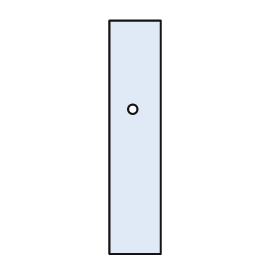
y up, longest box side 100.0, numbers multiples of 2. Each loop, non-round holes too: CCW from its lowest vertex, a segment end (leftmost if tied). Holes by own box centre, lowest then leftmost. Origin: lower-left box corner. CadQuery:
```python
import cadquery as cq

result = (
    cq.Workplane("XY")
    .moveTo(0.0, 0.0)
    .lineTo(22.0, 0.0)
    .lineTo(22.0, 100.0)
    .lineTo(0.0, 100.0)
    .close()
    .moveTo(10.0, 62.0)
    .circle(2.0)
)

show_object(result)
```